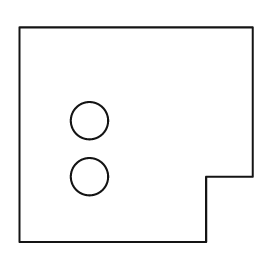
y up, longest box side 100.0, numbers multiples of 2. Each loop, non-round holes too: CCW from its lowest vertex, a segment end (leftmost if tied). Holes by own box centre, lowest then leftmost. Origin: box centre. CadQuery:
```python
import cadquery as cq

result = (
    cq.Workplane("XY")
    .moveTo(-50.0, -46.0)
    .lineTo(30.0, -46.0)
    .lineTo(30.0, -18.0)
    .lineTo(50.0, -18.0)
    .lineTo(50.0, 46.0)
    .lineTo(-50.0, 46.0)
    .close()
    .moveTo(-20.0, -18.0)
    .circle(8.0)
    .moveTo(-20.0, 6.0)
    .circle(8.0)
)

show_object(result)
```